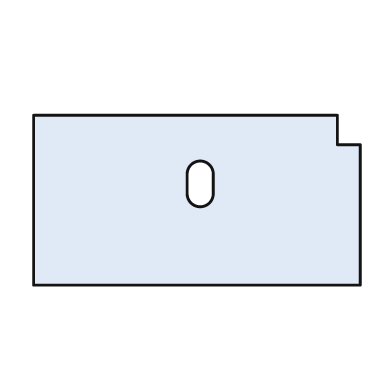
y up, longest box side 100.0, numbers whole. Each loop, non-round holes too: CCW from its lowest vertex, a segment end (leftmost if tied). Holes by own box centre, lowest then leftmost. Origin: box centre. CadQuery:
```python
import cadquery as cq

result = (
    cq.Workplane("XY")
    .moveTo(-50.0, -26.0)
    .lineTo(50.0, -26.0)
    .lineTo(50.0, 17.0)
    .lineTo(43.0, 17.0)
    .lineTo(43.0, 26.0)
    .lineTo(-50.0, 26.0)
    .close()
    .moveTo(-3.0, 2.0)
    .threePointArc((1.0, -2.0), (5.0, 2.0))
    .lineTo(5.0, 8.0)
    .threePointArc((1.0, 12.0), (-3.0, 8.0))
    .close()
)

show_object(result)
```